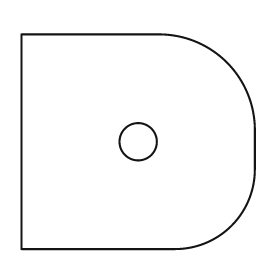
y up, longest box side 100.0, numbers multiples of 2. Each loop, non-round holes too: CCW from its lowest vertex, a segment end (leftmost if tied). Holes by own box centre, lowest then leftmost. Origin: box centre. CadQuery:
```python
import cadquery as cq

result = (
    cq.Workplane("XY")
    .moveTo(-50.0, -46.0)
    .lineTo(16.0, -46.0)
    .threePointArc((40.0, -36.0), (50.0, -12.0))
    .lineTo(50.0, 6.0)
    .threePointArc((38.0, 34.0), (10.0, 46.0))
    .lineTo(-50.0, 46.0)
    .close()
    .moveTo(0.0, 0.0)
    .circle(8.0)
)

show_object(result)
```